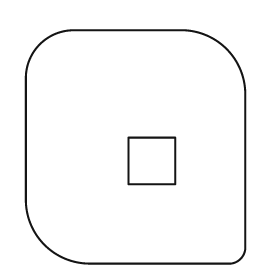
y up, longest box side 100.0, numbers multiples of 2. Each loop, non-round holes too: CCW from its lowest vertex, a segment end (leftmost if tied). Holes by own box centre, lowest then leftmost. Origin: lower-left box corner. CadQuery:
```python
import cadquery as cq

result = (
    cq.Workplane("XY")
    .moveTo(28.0, 0.0)
    .lineTo(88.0, 0.0)
    .threePointArc((92.0, 2.0), (94.0, 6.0))
    .lineTo(94.0, 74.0)
    .threePointArc((86.0, 92.0), (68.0, 100.0))
    .lineTo(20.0, 100.0)
    .threePointArc((6.0, 94.0), (0.0, 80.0))
    .lineTo(0.0, 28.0)
    .threePointArc((8.0, 8.0), (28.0, 0.0))
    .close()
    .moveTo(44.0, 34.0)
    .lineTo(64.0, 34.0)
    .lineTo(64.0, 54.0)
    .lineTo(44.0, 54.0)
    .close()
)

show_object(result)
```